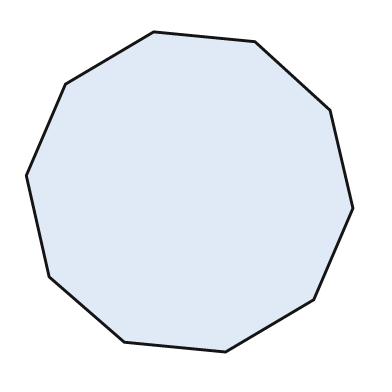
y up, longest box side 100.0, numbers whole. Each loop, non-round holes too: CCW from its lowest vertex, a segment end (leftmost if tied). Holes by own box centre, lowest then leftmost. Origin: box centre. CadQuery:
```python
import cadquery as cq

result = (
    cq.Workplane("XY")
    .moveTo(11.0, -49.0)
    .lineTo(38.0, -33.0)
    .lineTo(50.0, -5.0)
    .lineTo(43.0, 25.0)
    .lineTo(20.0, 46.0)
    .lineTo(-11.0, 49.0)
    .lineTo(-38.0, 33.0)
    .lineTo(-50.0, 5.0)
    .lineTo(-43.0, -26.0)
    .lineTo(-20.0, -46.0)
    .close()
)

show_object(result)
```